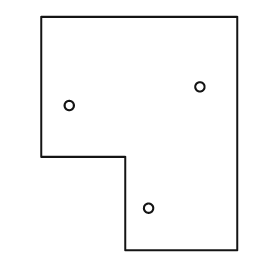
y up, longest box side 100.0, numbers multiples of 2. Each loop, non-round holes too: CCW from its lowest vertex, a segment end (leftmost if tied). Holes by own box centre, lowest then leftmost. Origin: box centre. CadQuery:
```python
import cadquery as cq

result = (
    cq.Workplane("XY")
    .moveTo(-6.0, -50.0)
    .lineTo(42.0, -50.0)
    .lineTo(42.0, 50.0)
    .lineTo(-42.0, 50.0)
    .lineTo(-42.0, -10.0)
    .lineTo(-6.0, -10.0)
    .close()
    .moveTo(4.0, -32.0)
    .circle(2.0)
    .moveTo(-30.0, 12.0)
    .circle(2.0)
    .moveTo(26.0, 20.0)
    .circle(2.0)
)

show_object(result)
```